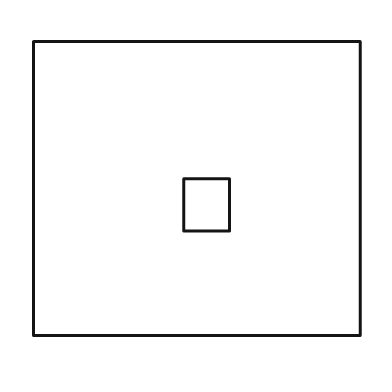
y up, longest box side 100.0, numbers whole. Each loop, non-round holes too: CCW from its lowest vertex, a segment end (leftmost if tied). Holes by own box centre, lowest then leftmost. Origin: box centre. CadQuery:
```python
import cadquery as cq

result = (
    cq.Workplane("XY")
    .moveTo(-50.0, -45.0)
    .lineTo(50.0, -45.0)
    .lineTo(50.0, 45.0)
    .lineTo(-50.0, 45.0)
    .close()
    .moveTo(-4.0, -13.0)
    .lineTo(10.0, -13.0)
    .lineTo(10.0, 3.0)
    .lineTo(-4.0, 3.0)
    .close()
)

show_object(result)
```